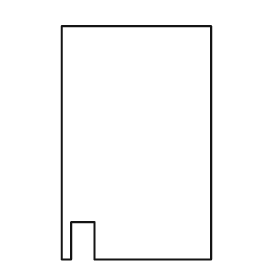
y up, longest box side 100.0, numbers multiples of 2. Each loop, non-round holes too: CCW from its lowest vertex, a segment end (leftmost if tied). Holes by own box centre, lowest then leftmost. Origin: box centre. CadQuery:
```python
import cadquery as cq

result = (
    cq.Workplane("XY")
    .moveTo(-32.0, -50.0)
    .lineTo(-28.0, -50.0)
    .lineTo(-28.0, -34.0)
    .lineTo(-18.0, -34.0)
    .lineTo(-18.0, -50.0)
    .lineTo(32.0, -50.0)
    .lineTo(32.0, 50.0)
    .lineTo(-32.0, 50.0)
    .close()
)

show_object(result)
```